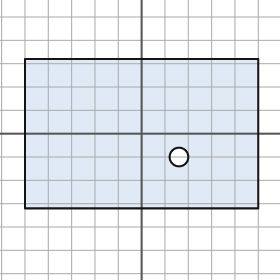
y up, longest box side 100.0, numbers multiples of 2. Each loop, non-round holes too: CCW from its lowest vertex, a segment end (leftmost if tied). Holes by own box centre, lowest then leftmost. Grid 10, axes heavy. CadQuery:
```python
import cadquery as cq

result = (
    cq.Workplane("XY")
    .moveTo(-50.0, -32.0)
    .lineTo(50.0, -32.0)
    .lineTo(50.0, 32.0)
    .lineTo(-50.0, 32.0)
    .close()
    .moveTo(16.0, -10.0)
    .circle(4.0)
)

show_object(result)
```